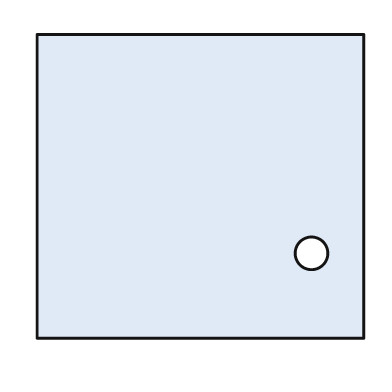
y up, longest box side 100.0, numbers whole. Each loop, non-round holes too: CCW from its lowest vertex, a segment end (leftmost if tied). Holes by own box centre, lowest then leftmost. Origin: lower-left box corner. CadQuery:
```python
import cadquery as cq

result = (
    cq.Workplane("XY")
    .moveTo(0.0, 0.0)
    .lineTo(100.0, 0.0)
    .lineTo(100.0, 93.0)
    .lineTo(0.0, 93.0)
    .close()
    .moveTo(84.0, 26.0)
    .circle(5.0)
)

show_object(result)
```